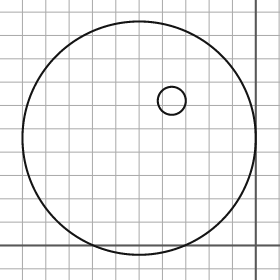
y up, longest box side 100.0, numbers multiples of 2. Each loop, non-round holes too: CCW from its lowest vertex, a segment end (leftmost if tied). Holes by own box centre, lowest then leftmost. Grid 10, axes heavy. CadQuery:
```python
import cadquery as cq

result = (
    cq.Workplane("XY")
    .moveTo(-50.0, 46.0)
    .circle(50.0)
    .moveTo(-36.0, 62.0)
    .circle(6.0)
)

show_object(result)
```